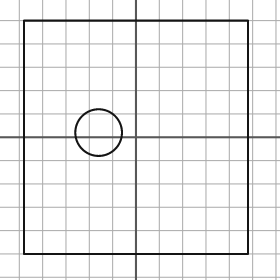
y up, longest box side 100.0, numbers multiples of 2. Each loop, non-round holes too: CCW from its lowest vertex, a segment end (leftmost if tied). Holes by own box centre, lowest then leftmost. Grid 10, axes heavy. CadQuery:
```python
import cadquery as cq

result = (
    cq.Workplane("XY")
    .moveTo(-48.0, -50.0)
    .lineTo(48.0, -50.0)
    .lineTo(48.0, 50.0)
    .lineTo(-48.0, 50.0)
    .close()
    .moveTo(-16.0, 2.0)
    .circle(10.0)
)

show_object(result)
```